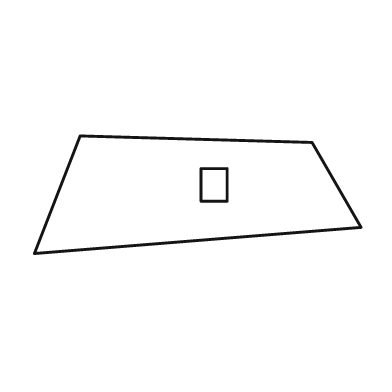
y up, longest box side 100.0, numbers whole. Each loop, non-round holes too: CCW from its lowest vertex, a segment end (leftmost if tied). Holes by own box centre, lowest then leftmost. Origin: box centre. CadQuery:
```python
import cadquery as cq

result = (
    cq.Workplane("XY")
    .moveTo(-50.0, -18.0)
    .lineTo(50.0, -10.0)
    .lineTo(35.0, 16.0)
    .lineTo(-36.0, 18.0)
    .close()
    .moveTo(1.0, -2.0)
    .lineTo(9.0, -2.0)
    .lineTo(9.0, 8.0)
    .lineTo(1.0, 8.0)
    .close()
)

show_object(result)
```